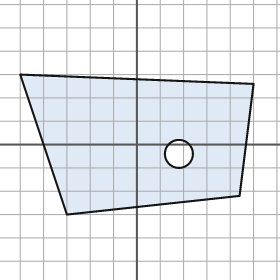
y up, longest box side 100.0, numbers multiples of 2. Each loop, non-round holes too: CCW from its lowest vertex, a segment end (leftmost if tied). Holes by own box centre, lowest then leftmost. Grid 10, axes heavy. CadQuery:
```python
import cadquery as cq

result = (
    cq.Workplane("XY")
    .moveTo(-30.0, -30.0)
    .lineTo(44.0, -22.0)
    .lineTo(50.0, 26.0)
    .lineTo(-50.0, 30.0)
    .close()
    .moveTo(18.0, -4.0)
    .circle(6.0)
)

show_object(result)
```